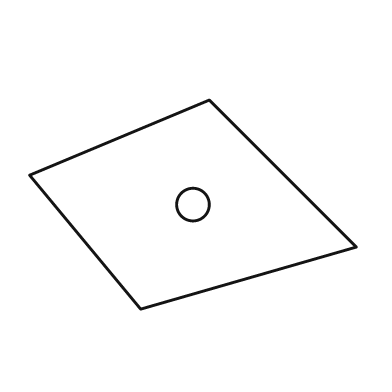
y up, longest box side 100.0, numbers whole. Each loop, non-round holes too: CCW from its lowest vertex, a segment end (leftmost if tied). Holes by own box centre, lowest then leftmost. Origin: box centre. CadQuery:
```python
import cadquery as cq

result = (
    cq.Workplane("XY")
    .moveTo(-16.0, -32.0)
    .lineTo(50.0, -13.0)
    .lineTo(5.0, 32.0)
    .lineTo(-50.0, 9.0)
    .close()
    .moveTo(0.0, 0.0)
    .circle(5.0)
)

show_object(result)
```